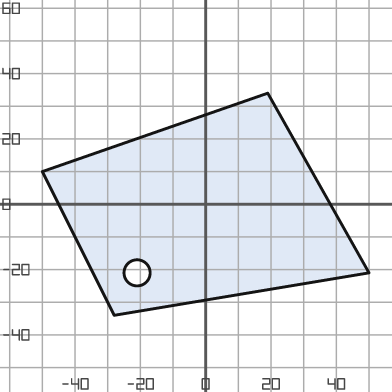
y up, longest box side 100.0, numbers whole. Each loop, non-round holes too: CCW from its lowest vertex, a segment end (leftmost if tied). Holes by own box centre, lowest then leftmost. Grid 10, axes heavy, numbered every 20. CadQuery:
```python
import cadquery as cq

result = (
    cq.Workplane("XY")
    .moveTo(-28.0, -34.0)
    .lineTo(50.0, -21.0)
    .lineTo(19.0, 34.0)
    .lineTo(-50.0, 10.0)
    .close()
    .moveTo(-21.0, -21.0)
    .circle(4.0)
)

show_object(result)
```